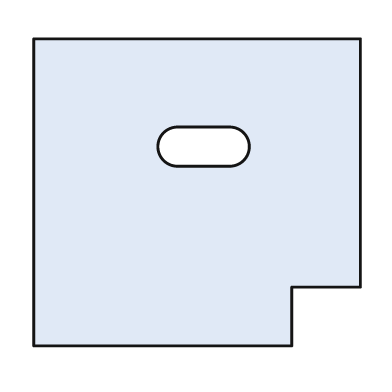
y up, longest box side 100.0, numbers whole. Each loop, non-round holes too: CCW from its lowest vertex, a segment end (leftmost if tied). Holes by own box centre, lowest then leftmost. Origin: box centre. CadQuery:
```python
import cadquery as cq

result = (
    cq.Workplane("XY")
    .moveTo(-50.0, -47.0)
    .lineTo(29.0, -47.0)
    .lineTo(29.0, -29.0)
    .lineTo(50.0, -29.0)
    .lineTo(50.0, 47.0)
    .lineTo(-50.0, 47.0)
    .close()
    .moveTo(-6.0, 8.0)
    .lineTo(10.0, 8.0)
    .threePointArc((16.0, 14.0), (10.0, 20.0))
    .lineTo(-6.0, 20.0)
    .threePointArc((-12.0, 14.0), (-6.0, 8.0))
    .close()
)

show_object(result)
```